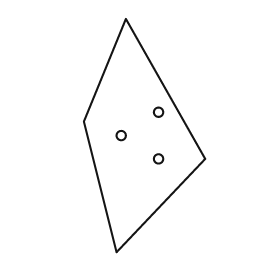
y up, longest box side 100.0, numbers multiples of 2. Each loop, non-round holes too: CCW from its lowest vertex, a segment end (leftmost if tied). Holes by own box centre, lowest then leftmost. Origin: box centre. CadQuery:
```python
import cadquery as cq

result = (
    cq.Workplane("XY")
    .moveTo(-12.0, -50.0)
    .lineTo(26.0, -10.0)
    .lineTo(-8.0, 50.0)
    .lineTo(-26.0, 6.0)
    .close()
    .moveTo(6.0, -10.0)
    .circle(2.0)
    .moveTo(-10.0, 0.0)
    .circle(2.0)
    .moveTo(6.0, 10.0)
    .circle(2.0)
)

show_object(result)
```